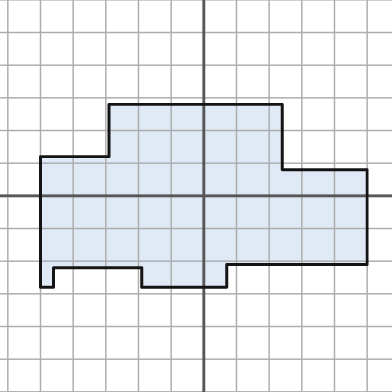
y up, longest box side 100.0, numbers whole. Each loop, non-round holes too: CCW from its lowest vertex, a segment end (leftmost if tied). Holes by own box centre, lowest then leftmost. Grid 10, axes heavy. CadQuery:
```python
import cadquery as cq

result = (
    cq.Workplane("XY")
    .moveTo(-50.0, -28.0)
    .lineTo(-46.0, -28.0)
    .lineTo(-46.0, -22.0)
    .lineTo(-19.0, -22.0)
    .lineTo(-19.0, -28.0)
    .lineTo(7.0, -28.0)
    .lineTo(7.0, -21.0)
    .lineTo(50.0, -21.0)
    .lineTo(50.0, 8.0)
    .lineTo(24.0, 8.0)
    .lineTo(24.0, 28.0)
    .lineTo(-29.0, 28.0)
    .lineTo(-29.0, 12.0)
    .lineTo(-50.0, 12.0)
    .close()
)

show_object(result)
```